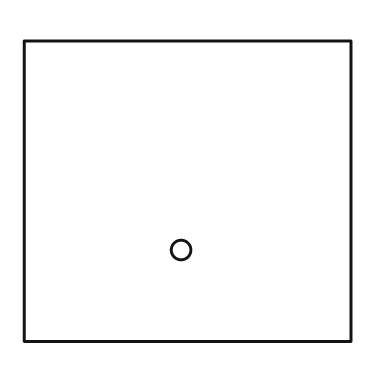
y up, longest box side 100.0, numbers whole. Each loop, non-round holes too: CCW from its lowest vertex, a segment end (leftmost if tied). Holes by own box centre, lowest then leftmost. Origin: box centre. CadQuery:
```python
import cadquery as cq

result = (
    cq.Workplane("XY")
    .moveTo(-50.0, -46.0)
    .lineTo(50.0, -46.0)
    .lineTo(50.0, 46.0)
    .lineTo(-50.0, 46.0)
    .close()
    .moveTo(-2.0, -18.0)
    .circle(3.0)
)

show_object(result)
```